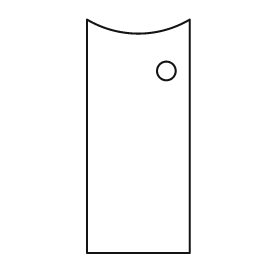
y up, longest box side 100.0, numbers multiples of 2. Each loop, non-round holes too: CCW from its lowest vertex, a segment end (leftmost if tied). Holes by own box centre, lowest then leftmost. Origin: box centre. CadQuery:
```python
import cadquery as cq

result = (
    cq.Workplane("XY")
    .moveTo(-22.0, -50.0)
    .lineTo(22.0, -50.0)
    .lineTo(22.0, 50.0)
    .threePointArc((0.0, 44.0), (-22.0, 50.0))
    .close()
    .moveTo(12.0, 28.0)
    .circle(4.0)
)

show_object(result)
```